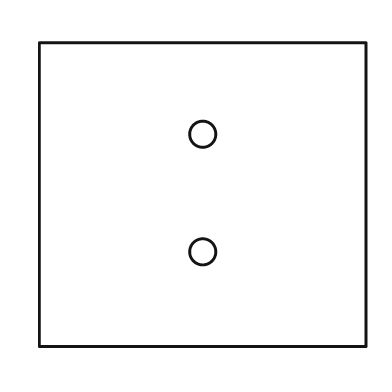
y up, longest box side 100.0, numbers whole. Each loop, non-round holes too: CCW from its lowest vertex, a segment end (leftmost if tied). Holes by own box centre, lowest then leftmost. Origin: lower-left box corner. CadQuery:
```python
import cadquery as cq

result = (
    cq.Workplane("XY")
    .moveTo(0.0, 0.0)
    .lineTo(100.0, 0.0)
    .lineTo(100.0, 93.0)
    .lineTo(0.0, 93.0)
    .close()
    .moveTo(50.0, 29.0)
    .circle(4.0)
    .moveTo(50.0, 65.0)
    .circle(4.0)
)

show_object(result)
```